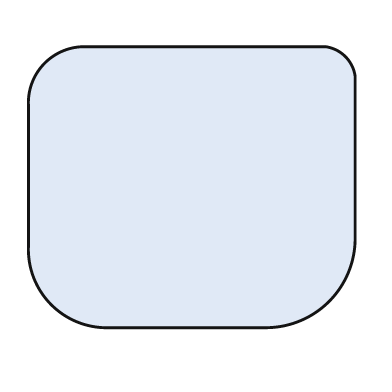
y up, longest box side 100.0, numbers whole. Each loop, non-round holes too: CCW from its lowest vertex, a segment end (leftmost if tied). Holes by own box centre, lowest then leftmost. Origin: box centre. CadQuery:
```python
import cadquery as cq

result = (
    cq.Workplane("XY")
    .moveTo(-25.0, -43.0)
    .lineTo(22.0, -43.0)
    .threePointArc((42.0, -35.0), (50.0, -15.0))
    .lineTo(50.0, 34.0)
    .threePointArc((47.0, 40.0), (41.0, 43.0))
    .lineTo(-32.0, 43.0)
    .threePointArc((-45.0, 38.0), (-50.0, 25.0))
    .lineTo(-50.0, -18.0)
    .threePointArc((-43.0, -36.0), (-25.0, -43.0))
    .close()
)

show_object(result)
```